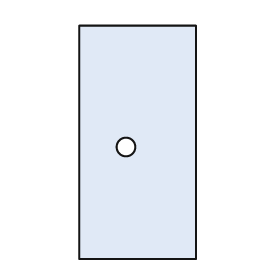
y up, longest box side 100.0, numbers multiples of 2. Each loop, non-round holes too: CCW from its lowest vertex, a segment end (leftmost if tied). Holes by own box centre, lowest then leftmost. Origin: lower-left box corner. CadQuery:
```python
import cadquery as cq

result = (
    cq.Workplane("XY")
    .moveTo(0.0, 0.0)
    .lineTo(50.0, 0.0)
    .lineTo(50.0, 100.0)
    .lineTo(0.0, 100.0)
    .close()
    .moveTo(20.0, 48.0)
    .circle(4.0)
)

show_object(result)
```